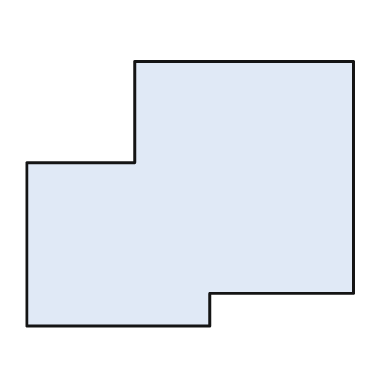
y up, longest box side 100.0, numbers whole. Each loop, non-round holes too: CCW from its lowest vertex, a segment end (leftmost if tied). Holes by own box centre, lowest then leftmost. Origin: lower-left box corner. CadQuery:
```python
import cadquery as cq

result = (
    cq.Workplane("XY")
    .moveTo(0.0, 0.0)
    .lineTo(56.0, 0.0)
    .lineTo(56.0, 10.0)
    .lineTo(100.0, 10.0)
    .lineTo(100.0, 81.0)
    .lineTo(33.0, 81.0)
    .lineTo(33.0, 50.0)
    .lineTo(0.0, 50.0)
    .close()
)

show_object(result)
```